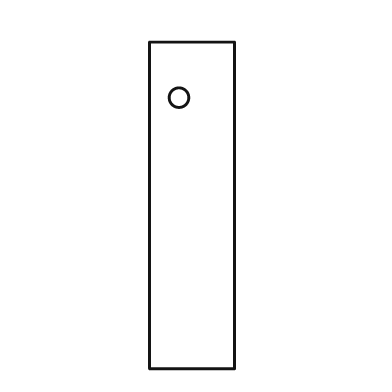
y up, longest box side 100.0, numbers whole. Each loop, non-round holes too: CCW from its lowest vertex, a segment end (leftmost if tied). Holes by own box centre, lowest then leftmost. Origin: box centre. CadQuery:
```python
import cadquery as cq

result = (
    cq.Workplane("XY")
    .moveTo(-13.0, -50.0)
    .lineTo(13.0, -50.0)
    .lineTo(13.0, 50.0)
    .lineTo(-13.0, 50.0)
    .close()
    .moveTo(-4.0, 33.0)
    .circle(3.0)
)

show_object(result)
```